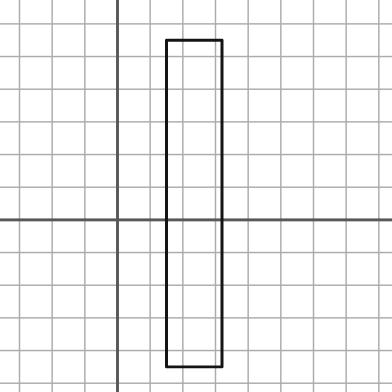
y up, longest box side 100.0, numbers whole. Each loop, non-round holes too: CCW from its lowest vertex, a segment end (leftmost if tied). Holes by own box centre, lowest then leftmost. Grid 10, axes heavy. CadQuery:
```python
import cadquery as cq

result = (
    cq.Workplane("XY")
    .moveTo(15.0, -45.0)
    .lineTo(32.0, -45.0)
    .lineTo(32.0, 55.0)
    .lineTo(15.0, 55.0)
    .close()
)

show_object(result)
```